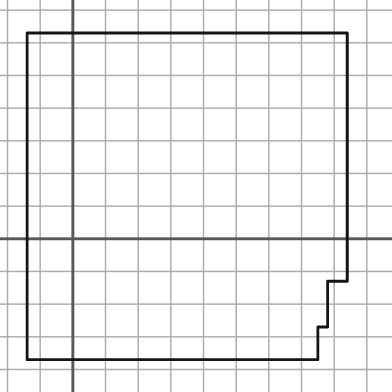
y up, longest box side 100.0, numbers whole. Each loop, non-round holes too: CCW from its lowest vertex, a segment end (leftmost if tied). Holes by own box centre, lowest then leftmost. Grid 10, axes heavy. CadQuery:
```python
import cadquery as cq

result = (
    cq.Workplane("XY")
    .moveTo(-14.0, -37.0)
    .lineTo(75.0, -37.0)
    .lineTo(75.0, -27.0)
    .lineTo(78.0, -27.0)
    .lineTo(78.0, -13.0)
    .lineTo(84.0, -13.0)
    .lineTo(84.0, 63.0)
    .lineTo(-14.0, 63.0)
    .close()
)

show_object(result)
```